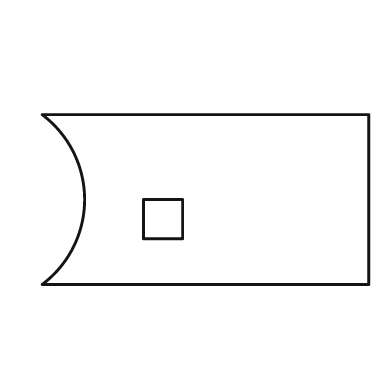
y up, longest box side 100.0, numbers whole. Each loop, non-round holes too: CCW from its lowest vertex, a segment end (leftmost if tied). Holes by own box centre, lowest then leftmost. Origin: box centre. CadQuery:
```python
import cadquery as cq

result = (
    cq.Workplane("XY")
    .moveTo(-50.0, -26.0)
    .lineTo(50.0, -26.0)
    .lineTo(50.0, 26.0)
    .lineTo(-50.0, 26.0)
    .threePointArc((-37.0, 0.0), (-50.0, -26.0))
    .close()
    .moveTo(-19.0, -12.0)
    .lineTo(-7.0, -12.0)
    .lineTo(-7.0, 0.0)
    .lineTo(-19.0, 0.0)
    .close()
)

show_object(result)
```